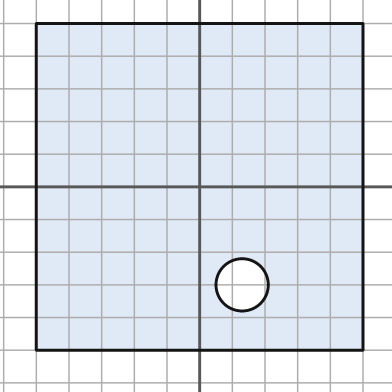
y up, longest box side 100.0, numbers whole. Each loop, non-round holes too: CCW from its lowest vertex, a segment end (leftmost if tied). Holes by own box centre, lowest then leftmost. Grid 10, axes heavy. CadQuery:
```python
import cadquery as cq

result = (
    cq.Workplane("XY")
    .moveTo(-50.0, -50.0)
    .lineTo(50.0, -50.0)
    .lineTo(50.0, 50.0)
    .lineTo(-50.0, 50.0)
    .close()
    .moveTo(13.0, -30.0)
    .circle(8.0)
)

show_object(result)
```